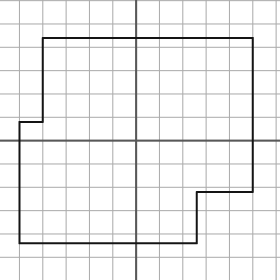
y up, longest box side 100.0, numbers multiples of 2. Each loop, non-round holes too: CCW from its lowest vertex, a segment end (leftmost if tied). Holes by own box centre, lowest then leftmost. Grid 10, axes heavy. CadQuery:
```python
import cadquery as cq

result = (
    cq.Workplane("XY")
    .moveTo(-50.0, -44.0)
    .lineTo(26.0, -44.0)
    .lineTo(26.0, -22.0)
    .lineTo(50.0, -22.0)
    .lineTo(50.0, 44.0)
    .lineTo(-40.0, 44.0)
    .lineTo(-40.0, 8.0)
    .lineTo(-50.0, 8.0)
    .close()
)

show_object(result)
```